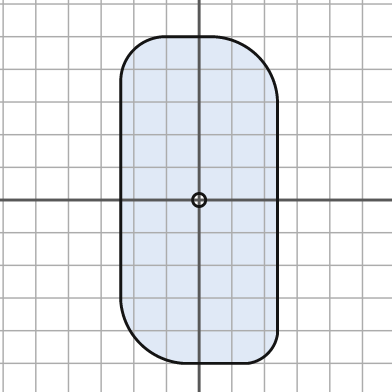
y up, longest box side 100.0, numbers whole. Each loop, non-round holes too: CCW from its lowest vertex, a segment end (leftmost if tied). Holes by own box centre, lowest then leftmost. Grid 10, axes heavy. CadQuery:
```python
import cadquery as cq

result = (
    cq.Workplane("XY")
    .moveTo(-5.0, -50.0)
    .lineTo(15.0, -50.0)
    .threePointArc((21.0, -47.0), (24.0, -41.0))
    .lineTo(24.0, 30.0)
    .threePointArc((18.0, 44.0), (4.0, 50.0))
    .lineTo(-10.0, 50.0)
    .threePointArc((-20.0, 46.0), (-24.0, 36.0))
    .lineTo(-24.0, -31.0)
    .threePointArc((-18.0, -44.0), (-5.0, -50.0))
    .close()
    .moveTo(0.0, 0.0)
    .circle(2.0)
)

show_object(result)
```